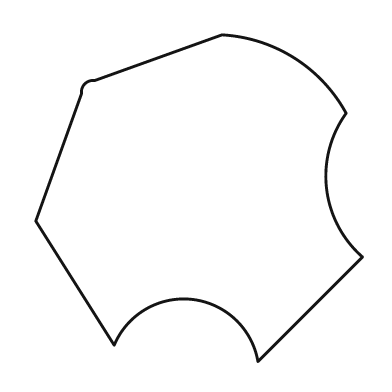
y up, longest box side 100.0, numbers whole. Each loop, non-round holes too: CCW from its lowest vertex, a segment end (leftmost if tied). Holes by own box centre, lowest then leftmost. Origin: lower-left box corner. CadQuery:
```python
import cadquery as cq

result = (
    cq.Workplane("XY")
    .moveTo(68.0, 0.0)
    .lineTo(100.0, 32.0)
    .threePointArc((89.0, 53.0), (95.0, 76.0))
    .threePointArc((79.0, 93.0), (57.0, 100.0))
    .lineTo(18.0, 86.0)
    .threePointArc((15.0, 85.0), (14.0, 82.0))
    .lineTo(0.0, 43.0)
    .lineTo(24.0, 5.0)
    .threePointArc((48.0, 19.0), (68.0, 0.0))
    .close()
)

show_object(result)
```